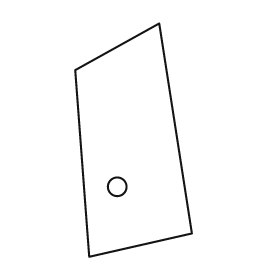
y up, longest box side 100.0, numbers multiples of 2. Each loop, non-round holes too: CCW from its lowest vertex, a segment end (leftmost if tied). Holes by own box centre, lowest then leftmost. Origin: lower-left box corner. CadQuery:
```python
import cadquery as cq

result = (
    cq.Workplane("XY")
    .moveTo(6.0, 0.0)
    .lineTo(50.0, 10.0)
    .lineTo(36.0, 100.0)
    .lineTo(0.0, 80.0)
    .close()
    .moveTo(18.0, 30.0)
    .circle(4.0)
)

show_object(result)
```